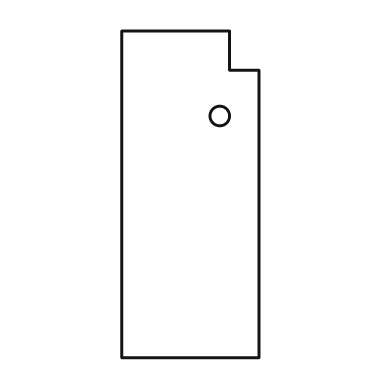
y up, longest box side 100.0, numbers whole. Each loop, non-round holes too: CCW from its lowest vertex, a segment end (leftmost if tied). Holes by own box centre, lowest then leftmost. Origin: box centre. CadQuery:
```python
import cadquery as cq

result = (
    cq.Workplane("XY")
    .moveTo(-21.0, -50.0)
    .lineTo(21.0, -50.0)
    .lineTo(21.0, 38.0)
    .lineTo(12.0, 38.0)
    .lineTo(12.0, 50.0)
    .lineTo(-21.0, 50.0)
    .close()
    .moveTo(9.0, 24.0)
    .circle(3.0)
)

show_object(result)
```